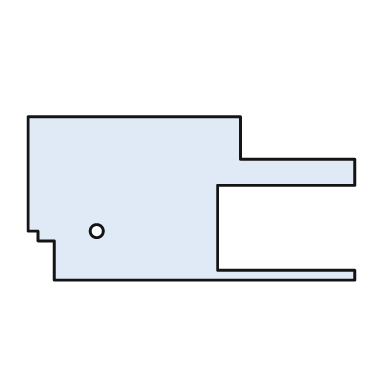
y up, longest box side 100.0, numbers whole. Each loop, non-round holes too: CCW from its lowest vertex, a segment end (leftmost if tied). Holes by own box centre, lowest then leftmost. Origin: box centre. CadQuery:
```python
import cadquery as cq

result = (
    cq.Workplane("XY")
    .moveTo(-42.0, -25.0)
    .lineTo(50.0, -25.0)
    .lineTo(50.0, -22.0)
    .lineTo(8.0, -22.0)
    .lineTo(8.0, 4.0)
    .lineTo(50.0, 4.0)
    .lineTo(50.0, 12.0)
    .lineTo(15.0, 12.0)
    .lineTo(15.0, 25.0)
    .lineTo(-50.0, 25.0)
    .lineTo(-50.0, -10.0)
    .lineTo(-47.0, -10.0)
    .lineTo(-47.0, -13.0)
    .lineTo(-42.0, -13.0)
    .close()
    .moveTo(-29.0, -10.0)
    .circle(2.0)
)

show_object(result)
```